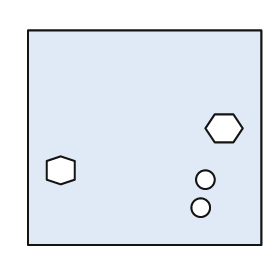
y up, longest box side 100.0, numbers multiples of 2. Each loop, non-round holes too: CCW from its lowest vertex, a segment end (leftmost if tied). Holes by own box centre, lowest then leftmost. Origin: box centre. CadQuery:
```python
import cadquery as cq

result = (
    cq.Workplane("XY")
    .moveTo(-50.0, -46.0)
    .lineTo(50.0, -46.0)
    .lineTo(50.0, 46.0)
    .lineTo(-50.0, 46.0)
    .close()
    .moveTo(24.0, -30.0)
    .circle(4.0)
    .moveTo(26.0, -18.0)
    .circle(4.0)
    .moveTo(-36.0, -20.0)
    .lineTo(-30.0, -18.0)
    .lineTo(-30.0, -10.0)
    .lineTo(-36.0, -8.0)
    .lineTo(-42.0, -10.0)
    .lineTo(-42.0, -18.0)
    .close()
    .moveTo(30.0, -2.0)
    .lineTo(38.0, -2.0)
    .lineTo(42.0, 4.0)
    .lineTo(38.0, 10.0)
    .lineTo(30.0, 10.0)
    .lineTo(26.0, 4.0)
    .close()
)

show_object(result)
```